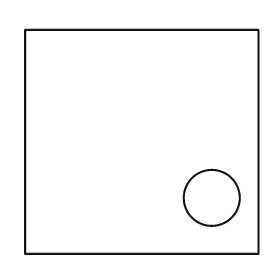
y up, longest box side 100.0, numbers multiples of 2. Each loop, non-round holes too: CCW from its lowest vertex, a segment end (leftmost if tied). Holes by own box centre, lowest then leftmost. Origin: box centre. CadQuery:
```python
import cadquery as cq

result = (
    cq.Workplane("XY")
    .moveTo(-50.0, -48.0)
    .lineTo(50.0, -48.0)
    .lineTo(50.0, 48.0)
    .lineTo(-50.0, 48.0)
    .close()
    .moveTo(30.0, -24.0)
    .circle(12.0)
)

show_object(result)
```